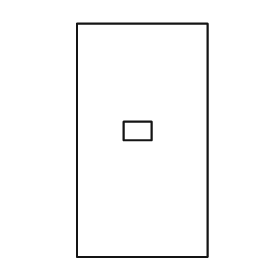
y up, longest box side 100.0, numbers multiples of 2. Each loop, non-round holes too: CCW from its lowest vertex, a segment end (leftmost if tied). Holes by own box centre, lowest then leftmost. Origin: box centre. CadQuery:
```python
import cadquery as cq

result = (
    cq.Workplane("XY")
    .moveTo(-28.0, -50.0)
    .lineTo(28.0, -50.0)
    .lineTo(28.0, 50.0)
    .lineTo(-28.0, 50.0)
    .close()
    .moveTo(-8.0, 0.0)
    .lineTo(4.0, 0.0)
    .lineTo(4.0, 8.0)
    .lineTo(-8.0, 8.0)
    .close()
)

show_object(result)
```